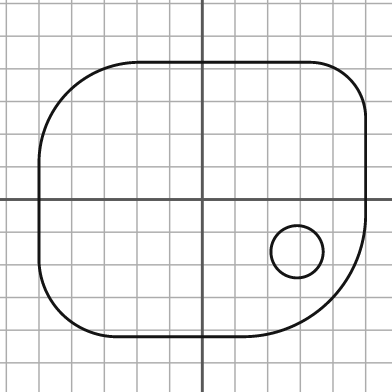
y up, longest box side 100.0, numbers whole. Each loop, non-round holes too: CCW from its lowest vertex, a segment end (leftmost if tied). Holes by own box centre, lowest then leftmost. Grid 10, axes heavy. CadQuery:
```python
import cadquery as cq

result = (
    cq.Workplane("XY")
    .moveTo(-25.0, -42.0)
    .lineTo(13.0, -42.0)
    .threePointArc((39.0, -31.0), (50.0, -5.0))
    .lineTo(50.0, 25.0)
    .threePointArc((45.0, 37.0), (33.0, 42.0))
    .lineTo(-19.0, 42.0)
    .threePointArc((-41.0, 33.0), (-50.0, 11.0))
    .lineTo(-50.0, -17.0)
    .threePointArc((-43.0, -35.0), (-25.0, -42.0))
    .close()
    .moveTo(29.0, -16.0)
    .circle(8.0)
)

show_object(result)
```